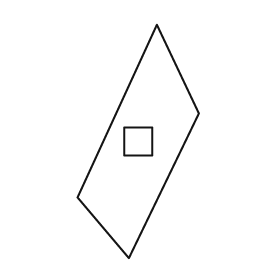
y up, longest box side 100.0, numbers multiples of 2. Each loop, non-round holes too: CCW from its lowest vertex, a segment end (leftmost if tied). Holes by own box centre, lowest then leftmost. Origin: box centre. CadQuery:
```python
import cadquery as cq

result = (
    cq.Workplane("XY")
    .moveTo(-4.0, -50.0)
    .lineTo(26.0, 12.0)
    .lineTo(8.0, 50.0)
    .lineTo(-26.0, -24.0)
    .close()
    .moveTo(-6.0, -6.0)
    .lineTo(6.0, -6.0)
    .lineTo(6.0, 6.0)
    .lineTo(-6.0, 6.0)
    .close()
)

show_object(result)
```